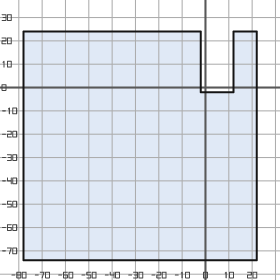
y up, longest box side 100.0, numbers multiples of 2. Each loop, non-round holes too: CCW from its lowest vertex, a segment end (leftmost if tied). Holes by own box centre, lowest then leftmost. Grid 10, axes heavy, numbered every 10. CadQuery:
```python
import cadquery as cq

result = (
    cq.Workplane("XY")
    .moveTo(-78.0, -74.0)
    .lineTo(22.0, -74.0)
    .lineTo(22.0, 24.0)
    .lineTo(12.0, 24.0)
    .lineTo(12.0, -2.0)
    .lineTo(-2.0, -2.0)
    .lineTo(-2.0, 24.0)
    .lineTo(-78.0, 24.0)
    .close()
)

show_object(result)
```